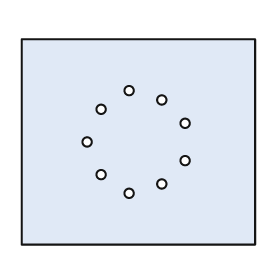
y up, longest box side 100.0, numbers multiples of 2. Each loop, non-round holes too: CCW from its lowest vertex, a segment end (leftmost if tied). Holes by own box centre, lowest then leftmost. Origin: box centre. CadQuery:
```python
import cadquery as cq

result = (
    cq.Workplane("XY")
    .moveTo(-50.0, -44.0)
    .lineTo(50.0, -44.0)
    .lineTo(50.0, 44.0)
    .lineTo(-50.0, 44.0)
    .close()
    .moveTo(-4.0, -22.0)
    .circle(2.0)
    .moveTo(10.0, -18.0)
    .circle(2.0)
    .moveTo(-16.0, -14.0)
    .circle(2.0)
    .moveTo(20.0, -8.0)
    .circle(2.0)
    .moveTo(-22.0, 0.0)
    .circle(2.0)
    .moveTo(20.0, 8.0)
    .circle(2.0)
    .moveTo(-16.0, 14.0)
    .circle(2.0)
    .moveTo(10.0, 18.0)
    .circle(2.0)
    .moveTo(-4.0, 22.0)
    .circle(2.0)
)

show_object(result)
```